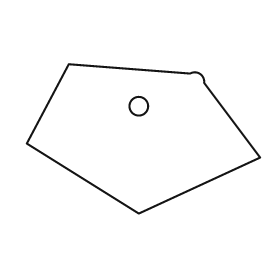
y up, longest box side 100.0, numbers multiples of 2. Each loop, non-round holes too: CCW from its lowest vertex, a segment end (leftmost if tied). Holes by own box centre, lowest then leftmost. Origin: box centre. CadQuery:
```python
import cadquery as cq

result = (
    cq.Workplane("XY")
    .moveTo(-2.0, -32.0)
    .lineTo(50.0, -8.0)
    .lineTo(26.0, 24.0)
    .threePointArc((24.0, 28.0), (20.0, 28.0))
    .lineTo(-32.0, 32.0)
    .lineTo(-50.0, -2.0)
    .close()
    .moveTo(-2.0, 14.0)
    .circle(4.0)
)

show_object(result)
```